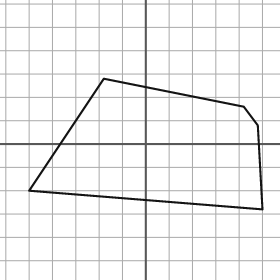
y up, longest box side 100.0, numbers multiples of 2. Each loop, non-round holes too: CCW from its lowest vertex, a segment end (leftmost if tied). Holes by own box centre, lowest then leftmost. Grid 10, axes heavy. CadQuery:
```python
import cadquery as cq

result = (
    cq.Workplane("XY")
    .moveTo(50.0, -28.0)
    .lineTo(48.0, 8.0)
    .lineTo(42.0, 16.0)
    .lineTo(-18.0, 28.0)
    .lineTo(-50.0, -20.0)
    .close()
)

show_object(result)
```